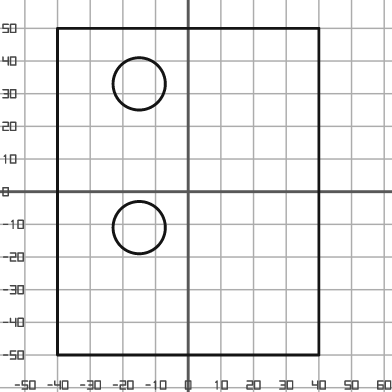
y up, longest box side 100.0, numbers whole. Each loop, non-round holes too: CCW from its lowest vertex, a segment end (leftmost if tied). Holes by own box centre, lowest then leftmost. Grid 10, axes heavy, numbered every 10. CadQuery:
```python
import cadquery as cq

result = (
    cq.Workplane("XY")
    .moveTo(-40.0, -50.0)
    .lineTo(40.0, -50.0)
    .lineTo(40.0, 50.0)
    .lineTo(-40.0, 50.0)
    .close()
    .moveTo(-15.0, -11.0)
    .circle(8.0)
    .moveTo(-15.0, 33.0)
    .circle(8.0)
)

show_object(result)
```